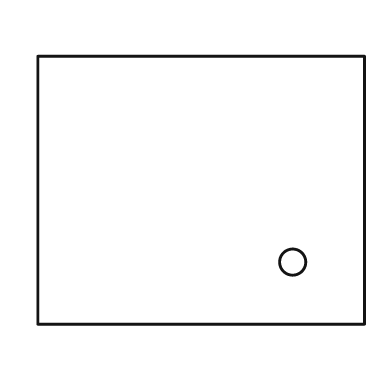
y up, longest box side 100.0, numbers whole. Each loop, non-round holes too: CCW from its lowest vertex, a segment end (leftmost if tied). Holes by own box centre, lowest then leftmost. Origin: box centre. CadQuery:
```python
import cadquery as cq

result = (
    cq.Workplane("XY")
    .moveTo(-50.0, -41.0)
    .lineTo(50.0, -41.0)
    .lineTo(50.0, 41.0)
    .lineTo(-50.0, 41.0)
    .close()
    .moveTo(28.0, -22.0)
    .circle(4.0)
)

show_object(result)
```